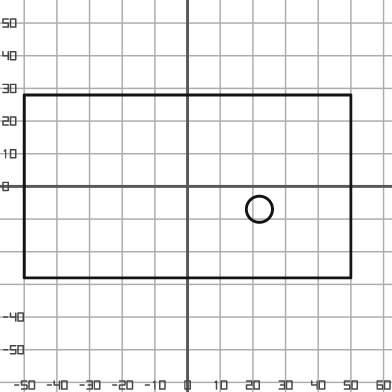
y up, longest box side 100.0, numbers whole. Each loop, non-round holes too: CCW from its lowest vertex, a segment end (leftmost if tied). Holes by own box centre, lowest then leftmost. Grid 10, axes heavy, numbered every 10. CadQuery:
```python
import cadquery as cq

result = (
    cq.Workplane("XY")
    .moveTo(-50.0, -28.0)
    .lineTo(50.0, -28.0)
    .lineTo(50.0, 28.0)
    .lineTo(-50.0, 28.0)
    .close()
    .moveTo(22.0, -7.0)
    .circle(4.0)
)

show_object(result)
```